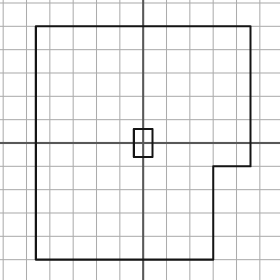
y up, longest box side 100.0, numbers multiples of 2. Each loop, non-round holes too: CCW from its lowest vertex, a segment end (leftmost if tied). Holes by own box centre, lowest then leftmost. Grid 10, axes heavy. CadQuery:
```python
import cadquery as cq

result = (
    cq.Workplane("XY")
    .moveTo(-46.0, -50.0)
    .lineTo(30.0, -50.0)
    .lineTo(30.0, -10.0)
    .lineTo(46.0, -10.0)
    .lineTo(46.0, 50.0)
    .lineTo(-46.0, 50.0)
    .close()
    .moveTo(-4.0, -6.0)
    .lineTo(4.0, -6.0)
    .lineTo(4.0, 6.0)
    .lineTo(-4.0, 6.0)
    .close()
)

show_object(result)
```